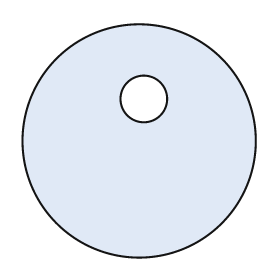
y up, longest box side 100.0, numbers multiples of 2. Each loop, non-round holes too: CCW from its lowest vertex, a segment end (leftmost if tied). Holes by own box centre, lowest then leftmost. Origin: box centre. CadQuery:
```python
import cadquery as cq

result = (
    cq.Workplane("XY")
    .moveTo(0.0, 0.0)
    .circle(50.0)
    .moveTo(2.0, 18.0)
    .circle(10.0)
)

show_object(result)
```